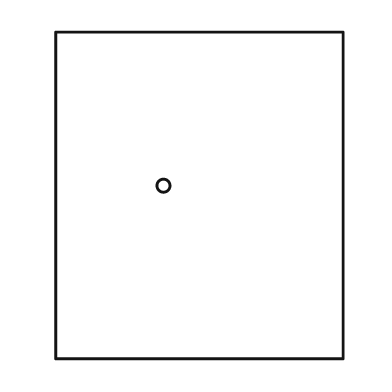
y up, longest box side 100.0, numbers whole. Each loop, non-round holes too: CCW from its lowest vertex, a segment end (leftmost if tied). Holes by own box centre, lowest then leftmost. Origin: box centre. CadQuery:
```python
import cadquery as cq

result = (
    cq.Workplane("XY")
    .moveTo(-44.0, -50.0)
    .lineTo(44.0, -50.0)
    .lineTo(44.0, 50.0)
    .lineTo(-44.0, 50.0)
    .close()
    .moveTo(-11.0, 3.0)
    .circle(2.0)
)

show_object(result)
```